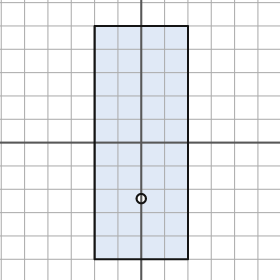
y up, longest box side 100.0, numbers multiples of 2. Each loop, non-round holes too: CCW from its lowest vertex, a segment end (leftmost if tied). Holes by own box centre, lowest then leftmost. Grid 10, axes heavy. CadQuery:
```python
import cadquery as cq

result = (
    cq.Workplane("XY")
    .moveTo(-20.0, -50.0)
    .lineTo(20.0, -50.0)
    .lineTo(20.0, 50.0)
    .lineTo(-20.0, 50.0)
    .close()
    .moveTo(0.0, -24.0)
    .circle(2.0)
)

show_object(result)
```